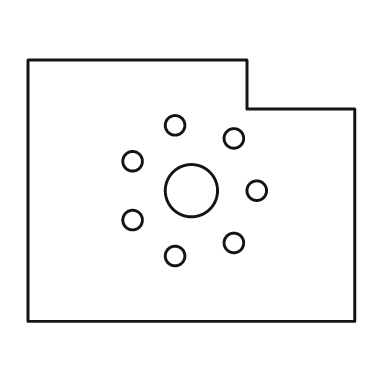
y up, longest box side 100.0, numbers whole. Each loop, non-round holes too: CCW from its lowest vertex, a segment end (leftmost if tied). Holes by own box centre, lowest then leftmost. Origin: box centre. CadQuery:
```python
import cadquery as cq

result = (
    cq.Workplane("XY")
    .moveTo(-50.0, -40.0)
    .lineTo(50.0, -40.0)
    .lineTo(50.0, 25.0)
    .lineTo(17.0, 25.0)
    .lineTo(17.0, 40.0)
    .lineTo(-50.0, 40.0)
    .close()
    .moveTo(-5.0, -20.0)
    .circle(3.0)
    .moveTo(13.0, -16.0)
    .circle(3.0)
    .moveTo(-18.0, -9.0)
    .circle(3.0)
    .moveTo(0.0, 0.0)
    .circle(8.0)
    .moveTo(20.0, 0.0)
    .circle(3.0)
    .moveTo(-18.0, 9.0)
    .circle(3.0)
    .moveTo(13.0, 16.0)
    .circle(3.0)
    .moveTo(-5.0, 20.0)
    .circle(3.0)
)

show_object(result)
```